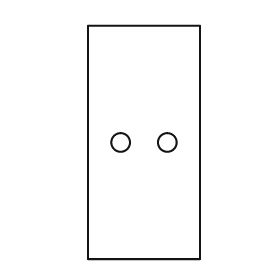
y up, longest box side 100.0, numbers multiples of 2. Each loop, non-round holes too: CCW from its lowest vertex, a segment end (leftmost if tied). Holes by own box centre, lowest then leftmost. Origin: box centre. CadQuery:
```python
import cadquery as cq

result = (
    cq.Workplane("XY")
    .moveTo(-24.0, -50.0)
    .lineTo(24.0, -50.0)
    .lineTo(24.0, 50.0)
    .lineTo(-24.0, 50.0)
    .close()
    .moveTo(-10.0, 0.0)
    .circle(4.0)
    .moveTo(10.0, 0.0)
    .circle(4.0)
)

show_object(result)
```